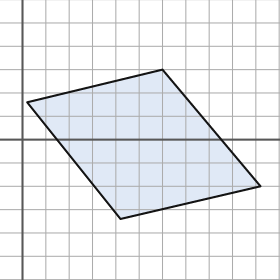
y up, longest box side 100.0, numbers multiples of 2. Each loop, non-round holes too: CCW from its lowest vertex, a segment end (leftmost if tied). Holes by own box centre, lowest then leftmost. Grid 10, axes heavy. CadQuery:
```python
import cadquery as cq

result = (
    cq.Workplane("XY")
    .moveTo(42.0, -34.0)
    .lineTo(102.0, -20.0)
    .lineTo(60.0, 30.0)
    .lineTo(2.0, 16.0)
    .close()
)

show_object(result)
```